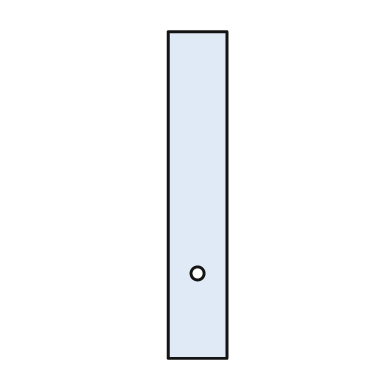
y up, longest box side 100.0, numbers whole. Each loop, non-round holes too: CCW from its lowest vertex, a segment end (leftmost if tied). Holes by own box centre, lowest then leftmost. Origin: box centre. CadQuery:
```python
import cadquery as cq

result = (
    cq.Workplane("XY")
    .moveTo(-9.0, -50.0)
    .lineTo(9.0, -50.0)
    .lineTo(9.0, 50.0)
    .lineTo(-9.0, 50.0)
    .close()
    .moveTo(0.0, -24.0)
    .circle(2.0)
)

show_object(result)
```